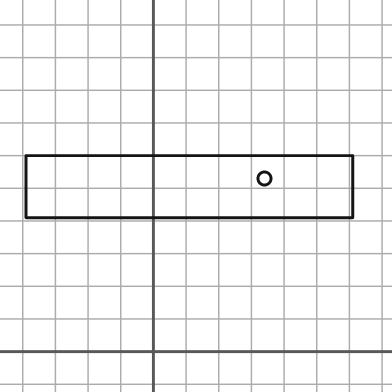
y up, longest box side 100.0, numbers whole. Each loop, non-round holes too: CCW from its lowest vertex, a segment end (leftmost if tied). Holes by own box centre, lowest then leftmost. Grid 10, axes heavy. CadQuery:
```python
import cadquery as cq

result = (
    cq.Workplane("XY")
    .moveTo(-39.0, 41.0)
    .lineTo(61.0, 41.0)
    .lineTo(61.0, 60.0)
    .lineTo(-39.0, 60.0)
    .close()
    .moveTo(34.0, 53.0)
    .circle(2.0)
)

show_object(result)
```